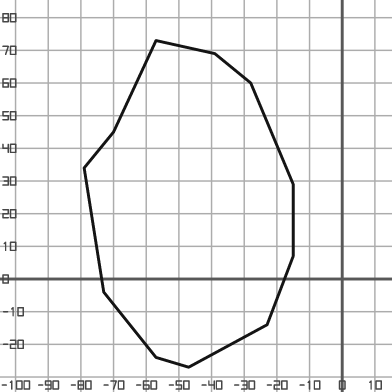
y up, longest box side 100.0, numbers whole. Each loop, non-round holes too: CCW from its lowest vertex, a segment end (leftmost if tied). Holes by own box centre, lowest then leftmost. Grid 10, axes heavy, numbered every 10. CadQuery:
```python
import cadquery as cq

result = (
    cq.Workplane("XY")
    .moveTo(-47.0, -27.0)
    .lineTo(-23.0, -14.0)
    .lineTo(-15.0, 7.0)
    .lineTo(-15.0, 29.0)
    .lineTo(-28.0, 60.0)
    .lineTo(-39.0, 69.0)
    .lineTo(-57.0, 73.0)
    .lineTo(-70.0, 45.0)
    .lineTo(-79.0, 34.0)
    .lineTo(-73.0, -4.0)
    .lineTo(-57.0, -24.0)
    .close()
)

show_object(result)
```